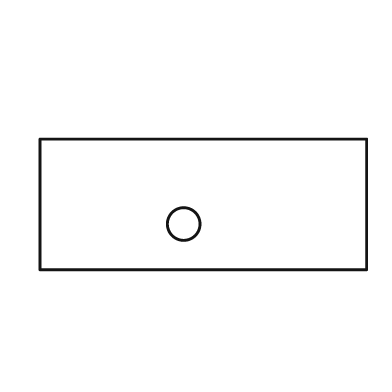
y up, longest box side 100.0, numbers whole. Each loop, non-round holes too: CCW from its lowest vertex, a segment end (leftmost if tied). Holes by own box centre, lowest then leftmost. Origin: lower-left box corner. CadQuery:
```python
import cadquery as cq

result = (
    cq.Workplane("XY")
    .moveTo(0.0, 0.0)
    .lineTo(100.0, 0.0)
    .lineTo(100.0, 40.0)
    .lineTo(0.0, 40.0)
    .close()
    .moveTo(44.0, 14.0)
    .circle(5.0)
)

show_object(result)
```